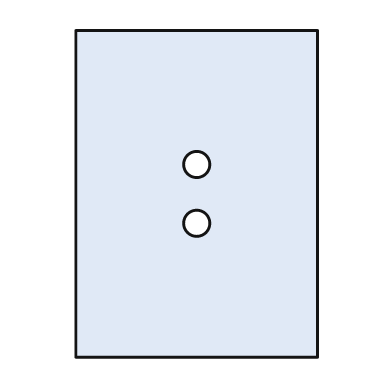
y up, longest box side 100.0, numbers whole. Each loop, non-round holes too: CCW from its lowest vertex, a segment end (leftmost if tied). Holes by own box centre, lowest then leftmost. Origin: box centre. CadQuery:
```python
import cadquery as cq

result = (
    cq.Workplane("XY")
    .moveTo(-37.0, -50.0)
    .lineTo(37.0, -50.0)
    .lineTo(37.0, 50.0)
    .lineTo(-37.0, 50.0)
    .close()
    .moveTo(0.0, -9.0)
    .circle(4.0)
    .moveTo(0.0, 9.0)
    .circle(4.0)
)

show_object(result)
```